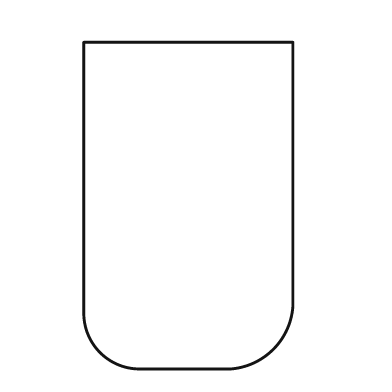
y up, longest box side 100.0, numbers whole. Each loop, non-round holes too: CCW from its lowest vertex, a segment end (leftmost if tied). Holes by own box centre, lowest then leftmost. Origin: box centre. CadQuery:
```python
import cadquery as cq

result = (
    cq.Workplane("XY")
    .moveTo(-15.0, -50.0)
    .lineTo(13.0, -50.0)
    .threePointArc((26.0, -44.0), (32.0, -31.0))
    .lineTo(32.0, 50.0)
    .lineTo(-32.0, 50.0)
    .lineTo(-32.0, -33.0)
    .threePointArc((-27.0, -45.0), (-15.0, -50.0))
    .close()
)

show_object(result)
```